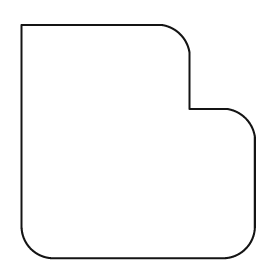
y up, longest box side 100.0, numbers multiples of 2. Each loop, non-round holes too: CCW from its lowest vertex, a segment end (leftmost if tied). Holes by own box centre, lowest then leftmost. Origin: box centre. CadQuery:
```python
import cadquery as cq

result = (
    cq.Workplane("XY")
    .moveTo(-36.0, -50.0)
    .lineTo(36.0, -50.0)
    .threePointArc((46.0, -46.0), (50.0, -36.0))
    .lineTo(50.0, 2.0)
    .threePointArc((46.0, 10.0), (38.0, 14.0))
    .lineTo(22.0, 14.0)
    .lineTo(22.0, 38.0)
    .threePointArc((18.0, 46.0), (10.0, 50.0))
    .lineTo(-50.0, 50.0)
    .lineTo(-50.0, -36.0)
    .threePointArc((-46.0, -46.0), (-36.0, -50.0))
    .close()
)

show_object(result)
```